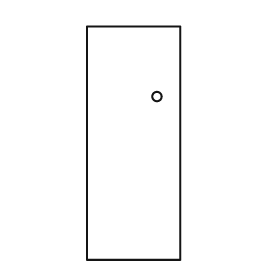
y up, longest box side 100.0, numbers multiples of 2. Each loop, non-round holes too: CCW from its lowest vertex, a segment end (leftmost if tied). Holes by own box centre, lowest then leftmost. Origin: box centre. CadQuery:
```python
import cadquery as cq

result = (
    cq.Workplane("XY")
    .moveTo(-20.0, -50.0)
    .lineTo(20.0, -50.0)
    .lineTo(20.0, 50.0)
    .lineTo(-20.0, 50.0)
    .close()
    .moveTo(10.0, 20.0)
    .circle(2.0)
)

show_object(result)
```